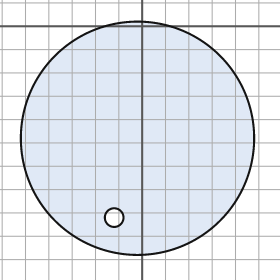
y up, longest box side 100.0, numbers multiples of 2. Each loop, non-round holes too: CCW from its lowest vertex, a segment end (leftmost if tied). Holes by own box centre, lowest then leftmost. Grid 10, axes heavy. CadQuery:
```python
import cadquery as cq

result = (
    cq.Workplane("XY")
    .moveTo(-2.0, -48.0)
    .circle(50.0)
    .moveTo(-12.0, -82.0)
    .circle(4.0)
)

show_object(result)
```